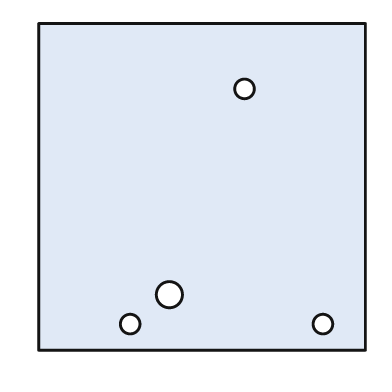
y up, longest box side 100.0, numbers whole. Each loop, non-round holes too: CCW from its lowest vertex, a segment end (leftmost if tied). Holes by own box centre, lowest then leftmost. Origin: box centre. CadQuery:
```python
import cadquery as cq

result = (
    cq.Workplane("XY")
    .moveTo(-50.0, -50.0)
    .lineTo(50.0, -50.0)
    .lineTo(50.0, 50.0)
    .lineTo(-50.0, 50.0)
    .close()
    .moveTo(-22.0, -42.0)
    .circle(3.0)
    .moveTo(37.0, -42.0)
    .circle(3.0)
    .moveTo(-10.0, -33.0)
    .circle(4.0)
    .moveTo(13.0, 30.0)
    .circle(3.0)
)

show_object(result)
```